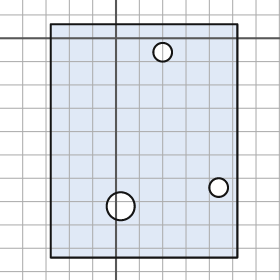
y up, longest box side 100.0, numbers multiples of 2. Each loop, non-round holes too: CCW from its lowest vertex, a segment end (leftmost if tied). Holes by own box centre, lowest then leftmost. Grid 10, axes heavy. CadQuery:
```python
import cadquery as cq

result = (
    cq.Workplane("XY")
    .moveTo(-28.0, -94.0)
    .lineTo(52.0, -94.0)
    .lineTo(52.0, 6.0)
    .lineTo(-28.0, 6.0)
    .close()
    .moveTo(2.0, -72.0)
    .circle(6.0)
    .moveTo(44.0, -64.0)
    .circle(4.0)
    .moveTo(20.0, -6.0)
    .circle(4.0)
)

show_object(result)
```